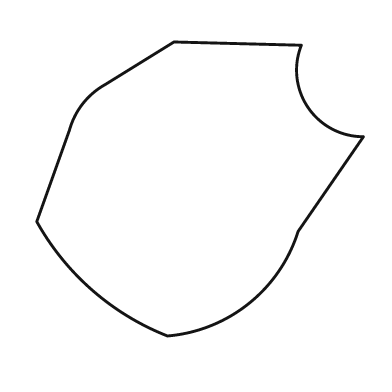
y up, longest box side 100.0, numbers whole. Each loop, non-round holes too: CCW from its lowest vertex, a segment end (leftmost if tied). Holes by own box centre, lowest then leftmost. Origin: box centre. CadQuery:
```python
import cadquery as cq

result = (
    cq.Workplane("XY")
    .moveTo(-10.0, -45.0)
    .threePointArc((15.0, -35.0), (30.0, -13.0))
    .lineTo(50.0, 16.0)
    .threePointArc((33.0, 25.0), (31.0, 44.0))
    .lineTo(-8.0, 45.0)
    .lineTo(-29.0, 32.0)
    .threePointArc((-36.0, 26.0), (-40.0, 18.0))
    .lineTo(-50.0, -10.0)
    .threePointArc((-33.0, -31.0), (-10.0, -45.0))
    .close()
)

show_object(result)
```